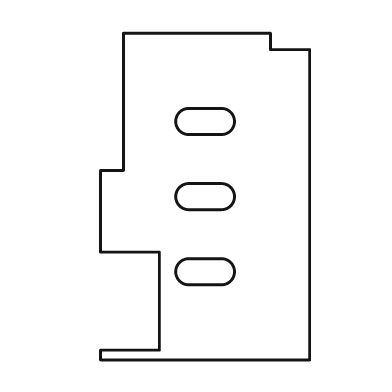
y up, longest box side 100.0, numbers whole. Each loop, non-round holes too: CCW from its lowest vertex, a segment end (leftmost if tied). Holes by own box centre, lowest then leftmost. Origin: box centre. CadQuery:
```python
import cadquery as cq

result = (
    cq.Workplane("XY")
    .moveTo(-32.0, -50.0)
    .lineTo(32.0, -50.0)
    .lineTo(32.0, 45.0)
    .lineTo(20.0, 45.0)
    .lineTo(20.0, 50.0)
    .lineTo(-25.0, 50.0)
    .lineTo(-25.0, 8.0)
    .lineTo(-32.0, 8.0)
    .lineTo(-32.0, -17.0)
    .lineTo(-14.0, -17.0)
    .lineTo(-14.0, -47.0)
    .lineTo(-32.0, -47.0)
    .close()
    .moveTo(-5.0, -27.0)
    .lineTo(5.0, -27.0)
    .threePointArc((9.0, -23.0), (5.0, -19.0))
    .lineTo(-5.0, -19.0)
    .threePointArc((-9.0, -23.0), (-5.0, -27.0))
    .close()
    .moveTo(-5.0, -4.0)
    .lineTo(5.0, -4.0)
    .threePointArc((9.0, 0.0), (5.0, 4.0))
    .lineTo(-5.0, 4.0)
    .threePointArc((-9.0, 0.0), (-5.0, -4.0))
    .close()
    .moveTo(-5.0, 19.0)
    .lineTo(5.0, 19.0)
    .threePointArc((9.0, 23.0), (5.0, 27.0))
    .lineTo(-5.0, 27.0)
    .threePointArc((-9.0, 23.0), (-5.0, 19.0))
    .close()
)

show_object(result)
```